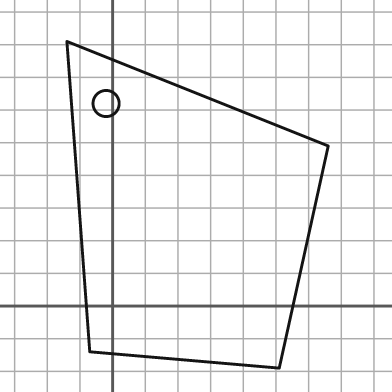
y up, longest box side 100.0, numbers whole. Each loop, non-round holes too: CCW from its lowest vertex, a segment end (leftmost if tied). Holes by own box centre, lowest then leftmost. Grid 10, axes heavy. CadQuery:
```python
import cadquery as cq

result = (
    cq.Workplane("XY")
    .moveTo(51.0, -19.0)
    .lineTo(66.0, 49.0)
    .lineTo(-14.0, 81.0)
    .lineTo(-7.0, -14.0)
    .close()
    .moveTo(-2.0, 62.0)
    .circle(4.0)
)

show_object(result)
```